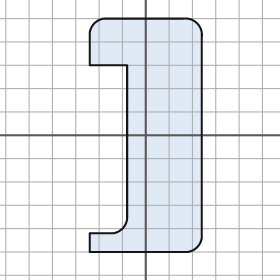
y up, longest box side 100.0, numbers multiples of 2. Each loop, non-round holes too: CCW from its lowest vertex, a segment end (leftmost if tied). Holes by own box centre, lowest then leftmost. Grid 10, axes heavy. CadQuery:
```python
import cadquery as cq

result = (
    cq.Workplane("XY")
    .moveTo(-24.0, -50.0)
    .lineTo(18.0, -50.0)
    .threePointArc((22.0, -48.0), (24.0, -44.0))
    .lineTo(24.0, 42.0)
    .threePointArc((22.0, 48.0), (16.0, 50.0))
    .lineTo(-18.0, 50.0)
    .threePointArc((-22.0, 48.0), (-24.0, 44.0))
    .lineTo(-24.0, 30.0)
    .lineTo(-8.0, 30.0)
    .lineTo(-8.0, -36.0)
    .threePointArc((-10.0, -40.0), (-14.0, -42.0))
    .lineTo(-24.0, -42.0)
    .close()
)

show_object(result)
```